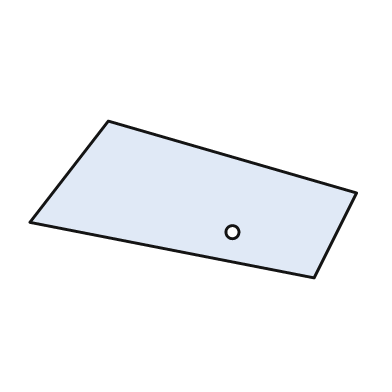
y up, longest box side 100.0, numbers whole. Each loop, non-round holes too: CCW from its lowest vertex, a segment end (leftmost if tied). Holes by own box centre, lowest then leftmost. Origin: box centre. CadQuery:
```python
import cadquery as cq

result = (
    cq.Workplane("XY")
    .moveTo(37.0, -24.0)
    .lineTo(50.0, 2.0)
    .lineTo(-26.0, 24.0)
    .lineTo(-50.0, -7.0)
    .close()
    .moveTo(12.0, -10.0)
    .circle(2.0)
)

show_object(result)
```